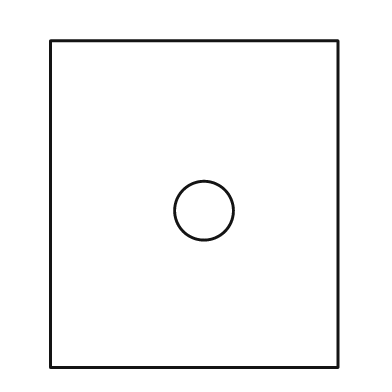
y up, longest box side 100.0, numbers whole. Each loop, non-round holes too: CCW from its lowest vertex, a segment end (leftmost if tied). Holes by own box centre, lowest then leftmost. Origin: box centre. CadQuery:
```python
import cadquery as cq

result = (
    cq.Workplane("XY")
    .moveTo(-44.0, -50.0)
    .lineTo(44.0, -50.0)
    .lineTo(44.0, 50.0)
    .lineTo(-44.0, 50.0)
    .close()
    .moveTo(3.0, -2.0)
    .circle(9.0)
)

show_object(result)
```